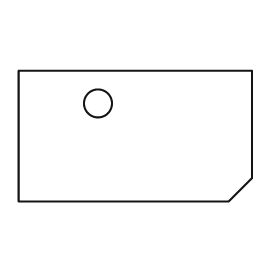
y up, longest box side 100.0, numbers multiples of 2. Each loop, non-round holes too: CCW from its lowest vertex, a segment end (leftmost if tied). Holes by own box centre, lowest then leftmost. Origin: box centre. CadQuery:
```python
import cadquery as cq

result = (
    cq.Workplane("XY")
    .moveTo(-50.0, -28.0)
    .lineTo(40.0, -28.0)
    .lineTo(50.0, -18.0)
    .lineTo(50.0, 28.0)
    .lineTo(-50.0, 28.0)
    .close()
    .moveTo(-16.0, 14.0)
    .circle(6.0)
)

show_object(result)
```